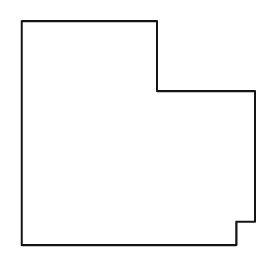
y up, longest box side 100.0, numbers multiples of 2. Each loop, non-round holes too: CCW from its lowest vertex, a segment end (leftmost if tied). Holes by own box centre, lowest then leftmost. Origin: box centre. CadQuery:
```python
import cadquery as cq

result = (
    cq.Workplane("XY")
    .moveTo(-50.0, -48.0)
    .lineTo(42.0, -48.0)
    .lineTo(42.0, -38.0)
    .lineTo(50.0, -38.0)
    .lineTo(50.0, 18.0)
    .lineTo(8.0, 18.0)
    .lineTo(8.0, 48.0)
    .lineTo(-50.0, 48.0)
    .close()
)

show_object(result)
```